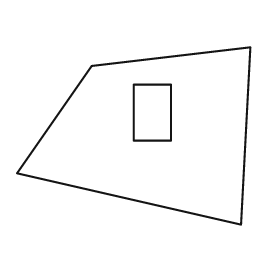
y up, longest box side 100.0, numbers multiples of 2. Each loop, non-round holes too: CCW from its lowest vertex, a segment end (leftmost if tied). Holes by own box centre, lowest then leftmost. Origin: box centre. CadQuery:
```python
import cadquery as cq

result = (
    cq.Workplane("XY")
    .moveTo(46.0, -38.0)
    .lineTo(50.0, 38.0)
    .lineTo(-18.0, 30.0)
    .lineTo(-50.0, -16.0)
    .close()
    .moveTo(0.0, -2.0)
    .lineTo(16.0, -2.0)
    .lineTo(16.0, 22.0)
    .lineTo(0.0, 22.0)
    .close()
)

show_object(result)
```